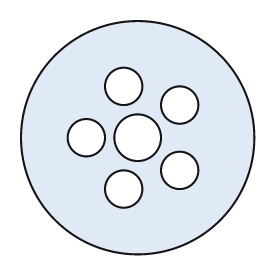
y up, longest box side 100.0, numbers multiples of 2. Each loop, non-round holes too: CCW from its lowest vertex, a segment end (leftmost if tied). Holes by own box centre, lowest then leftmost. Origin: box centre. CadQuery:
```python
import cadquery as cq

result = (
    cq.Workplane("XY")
    .moveTo(0.0, 0.0)
    .circle(50.0)
    .moveTo(-6.0, -22.0)
    .circle(8.0)
    .moveTo(18.0, -14.0)
    .circle(8.0)
    .moveTo(-22.0, 0.0)
    .circle(8.0)
    .moveTo(0.0, 0.0)
    .circle(10.0)
    .moveTo(18.0, 14.0)
    .circle(8.0)
    .moveTo(-6.0, 22.0)
    .circle(8.0)
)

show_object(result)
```